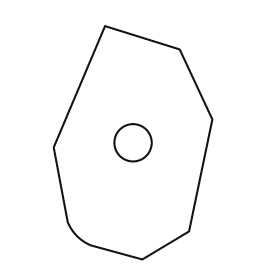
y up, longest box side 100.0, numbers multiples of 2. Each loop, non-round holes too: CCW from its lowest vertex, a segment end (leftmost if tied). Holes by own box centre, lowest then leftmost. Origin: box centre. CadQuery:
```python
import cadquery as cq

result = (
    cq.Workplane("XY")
    .moveTo(4.0, -50.0)
    .lineTo(24.0, -38.0)
    .lineTo(34.0, 10.0)
    .lineTo(20.0, 40.0)
    .lineTo(-12.0, 50.0)
    .lineTo(-34.0, -2.0)
    .lineTo(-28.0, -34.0)
    .threePointArc((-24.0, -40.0), (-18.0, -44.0))
    .close()
    .moveTo(0.0, 0.0)
    .circle(8.0)
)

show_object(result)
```